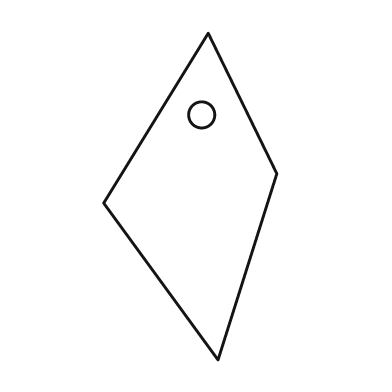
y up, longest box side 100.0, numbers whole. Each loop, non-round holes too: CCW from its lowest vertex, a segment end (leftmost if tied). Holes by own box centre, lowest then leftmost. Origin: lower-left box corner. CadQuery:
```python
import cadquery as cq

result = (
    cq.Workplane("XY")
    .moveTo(35.0, 0.0)
    .lineTo(53.0, 57.0)
    .lineTo(32.0, 100.0)
    .lineTo(0.0, 48.0)
    .close()
    .moveTo(30.0, 75.0)
    .circle(4.0)
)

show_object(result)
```